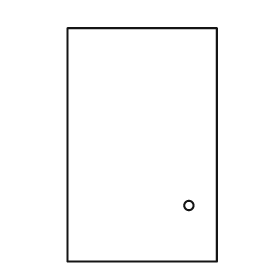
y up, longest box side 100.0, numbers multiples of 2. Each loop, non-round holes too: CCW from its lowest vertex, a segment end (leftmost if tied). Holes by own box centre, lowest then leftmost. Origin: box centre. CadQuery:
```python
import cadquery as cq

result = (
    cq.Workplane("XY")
    .moveTo(-32.0, -50.0)
    .lineTo(32.0, -50.0)
    .lineTo(32.0, 50.0)
    .lineTo(-32.0, 50.0)
    .close()
    .moveTo(20.0, -26.0)
    .circle(2.0)
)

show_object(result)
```